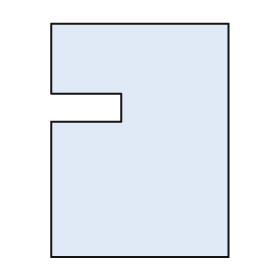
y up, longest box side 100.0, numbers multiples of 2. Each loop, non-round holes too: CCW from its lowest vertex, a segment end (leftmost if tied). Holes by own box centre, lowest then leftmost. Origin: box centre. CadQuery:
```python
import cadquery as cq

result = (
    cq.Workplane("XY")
    .moveTo(-38.0, -50.0)
    .lineTo(38.0, -50.0)
    .lineTo(38.0, 50.0)
    .lineTo(-38.0, 50.0)
    .lineTo(-38.0, 20.0)
    .lineTo(-8.0, 20.0)
    .lineTo(-8.0, 8.0)
    .lineTo(-38.0, 8.0)
    .close()
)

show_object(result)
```